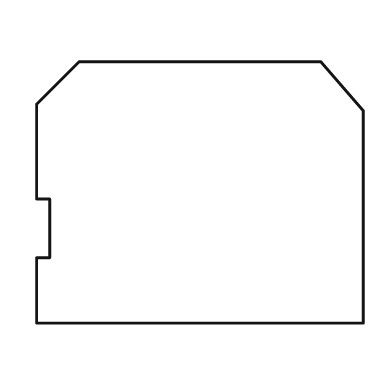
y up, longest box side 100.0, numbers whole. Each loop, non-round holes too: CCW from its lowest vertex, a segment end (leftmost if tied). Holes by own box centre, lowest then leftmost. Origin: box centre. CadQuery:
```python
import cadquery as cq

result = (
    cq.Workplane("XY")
    .moveTo(-50.0, -40.0)
    .lineTo(50.0, -40.0)
    .lineTo(50.0, 25.0)
    .lineTo(37.0, 40.0)
    .lineTo(-37.0, 40.0)
    .lineTo(-50.0, 27.0)
    .lineTo(-50.0, -2.0)
    .lineTo(-46.0, -2.0)
    .lineTo(-46.0, -20.0)
    .lineTo(-50.0, -20.0)
    .close()
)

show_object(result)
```